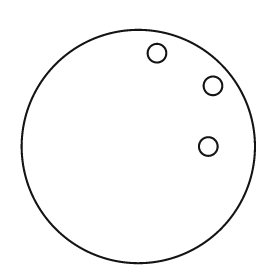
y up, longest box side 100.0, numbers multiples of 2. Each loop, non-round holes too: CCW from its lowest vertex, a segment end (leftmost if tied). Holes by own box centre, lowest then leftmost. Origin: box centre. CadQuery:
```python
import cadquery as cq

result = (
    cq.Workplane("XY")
    .moveTo(0.0, 0.0)
    .circle(50.0)
    .moveTo(30.0, 0.0)
    .circle(4.0)
    .moveTo(32.0, 26.0)
    .circle(4.0)
    .moveTo(8.0, 40.0)
    .circle(4.0)
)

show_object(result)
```